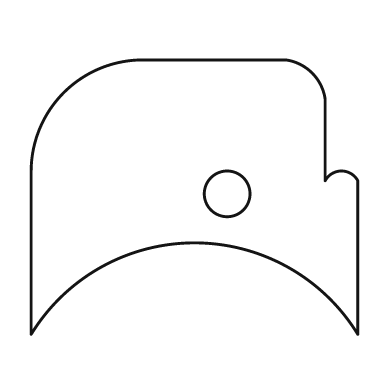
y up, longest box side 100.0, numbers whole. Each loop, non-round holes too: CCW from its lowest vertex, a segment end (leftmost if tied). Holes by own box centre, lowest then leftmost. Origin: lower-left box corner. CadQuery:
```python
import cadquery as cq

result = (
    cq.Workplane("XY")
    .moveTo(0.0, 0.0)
    .threePointArc((50.0, 28.0), (100.0, 0.0))
    .lineTo(100.0, 47.0)
    .threePointArc((95.0, 50.0), (90.0, 47.0))
    .lineTo(90.0, 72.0)
    .threePointArc((86.0, 80.0), (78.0, 84.0))
    .lineTo(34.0, 84.0)
    .threePointArc((10.0, 74.0), (0.0, 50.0))
    .close()
    .moveTo(60.0, 43.0)
    .circle(7.0)
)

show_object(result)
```